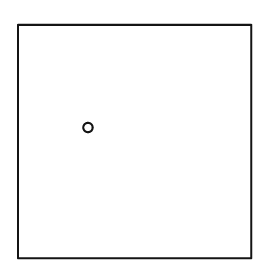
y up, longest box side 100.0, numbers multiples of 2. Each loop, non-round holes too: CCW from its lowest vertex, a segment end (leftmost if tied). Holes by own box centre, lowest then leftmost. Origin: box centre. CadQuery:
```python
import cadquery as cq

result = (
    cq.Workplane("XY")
    .moveTo(-50.0, -50.0)
    .lineTo(50.0, -50.0)
    .lineTo(50.0, 50.0)
    .lineTo(-50.0, 50.0)
    .close()
    .moveTo(-20.0, 6.0)
    .circle(2.0)
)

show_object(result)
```